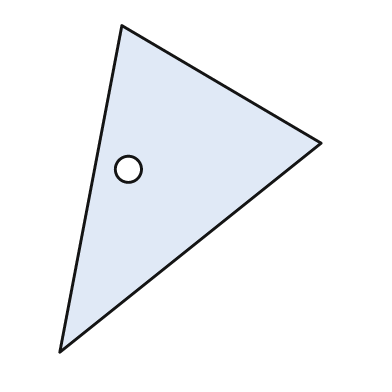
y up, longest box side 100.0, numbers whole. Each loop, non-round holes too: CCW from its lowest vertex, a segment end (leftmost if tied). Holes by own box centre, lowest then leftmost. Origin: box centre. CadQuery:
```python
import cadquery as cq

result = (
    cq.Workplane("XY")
    .moveTo(-40.0, -50.0)
    .lineTo(40.0, 14.0)
    .lineTo(-21.0, 50.0)
    .close()
    .moveTo(-19.0, 6.0)
    .circle(4.0)
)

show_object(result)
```